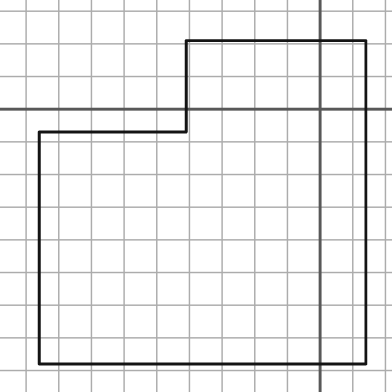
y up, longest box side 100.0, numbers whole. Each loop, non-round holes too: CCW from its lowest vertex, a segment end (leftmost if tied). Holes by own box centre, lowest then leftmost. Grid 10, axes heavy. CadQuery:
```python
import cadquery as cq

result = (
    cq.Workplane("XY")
    .moveTo(-86.0, -78.0)
    .lineTo(14.0, -78.0)
    .lineTo(14.0, 21.0)
    .lineTo(-41.0, 21.0)
    .lineTo(-41.0, -7.0)
    .lineTo(-86.0, -7.0)
    .close()
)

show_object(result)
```